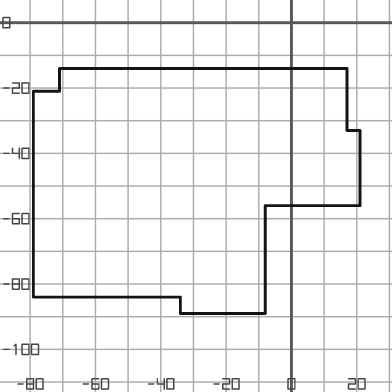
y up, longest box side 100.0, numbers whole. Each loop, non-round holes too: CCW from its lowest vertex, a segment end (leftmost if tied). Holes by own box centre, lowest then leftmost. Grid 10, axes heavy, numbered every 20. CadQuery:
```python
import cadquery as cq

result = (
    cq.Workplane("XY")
    .moveTo(-34.0, -89.0)
    .lineTo(-8.0, -89.0)
    .lineTo(-8.0, -56.0)
    .lineTo(21.0, -56.0)
    .lineTo(21.0, -33.0)
    .lineTo(17.0, -33.0)
    .lineTo(17.0, -14.0)
    .lineTo(-71.0, -14.0)
    .lineTo(-71.0, -21.0)
    .lineTo(-79.0, -21.0)
    .lineTo(-79.0, -84.0)
    .lineTo(-34.0, -84.0)
    .close()
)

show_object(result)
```